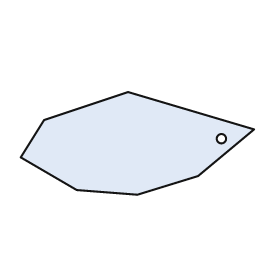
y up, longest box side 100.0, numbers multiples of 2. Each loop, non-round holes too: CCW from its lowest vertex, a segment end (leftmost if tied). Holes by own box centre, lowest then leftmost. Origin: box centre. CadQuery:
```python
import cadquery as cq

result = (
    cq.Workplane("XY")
    .moveTo(0.0, -22.0)
    .lineTo(26.0, -14.0)
    .lineTo(50.0, 6.0)
    .lineTo(-4.0, 22.0)
    .lineTo(-40.0, 10.0)
    .lineTo(-50.0, -6.0)
    .lineTo(-26.0, -20.0)
    .close()
    .moveTo(36.0, 2.0)
    .circle(2.0)
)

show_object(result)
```